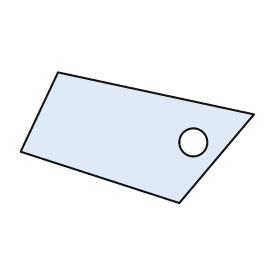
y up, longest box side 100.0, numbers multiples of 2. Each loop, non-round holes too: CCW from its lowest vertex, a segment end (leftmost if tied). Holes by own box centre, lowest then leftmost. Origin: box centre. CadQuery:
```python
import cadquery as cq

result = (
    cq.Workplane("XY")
    .moveTo(18.0, -28.0)
    .lineTo(50.0, 10.0)
    .lineTo(-34.0, 28.0)
    .lineTo(-50.0, -6.0)
    .close()
    .moveTo(24.0, -2.0)
    .circle(6.0)
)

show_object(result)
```